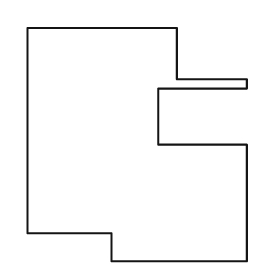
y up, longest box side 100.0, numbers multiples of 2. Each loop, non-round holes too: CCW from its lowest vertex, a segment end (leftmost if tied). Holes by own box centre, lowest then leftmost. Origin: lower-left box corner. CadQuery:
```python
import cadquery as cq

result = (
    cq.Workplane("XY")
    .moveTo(36.0, 0.0)
    .lineTo(94.0, 0.0)
    .lineTo(94.0, 50.0)
    .lineTo(56.0, 50.0)
    .lineTo(56.0, 74.0)
    .lineTo(94.0, 74.0)
    .lineTo(94.0, 78.0)
    .lineTo(64.0, 78.0)
    .lineTo(64.0, 100.0)
    .lineTo(0.0, 100.0)
    .lineTo(0.0, 12.0)
    .lineTo(36.0, 12.0)
    .close()
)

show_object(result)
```